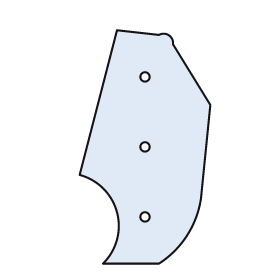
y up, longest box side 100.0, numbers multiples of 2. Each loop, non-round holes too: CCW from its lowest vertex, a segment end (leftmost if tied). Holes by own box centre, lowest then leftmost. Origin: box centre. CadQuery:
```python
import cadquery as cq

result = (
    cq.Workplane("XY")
    .moveTo(-18.0, -50.0)
    .lineTo(6.0, -50.0)
    .threePointArc((18.0, -38.0), (24.0, -22.0))
    .lineTo(28.0, 18.0)
    .lineTo(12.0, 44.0)
    .threePointArc((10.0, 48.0), (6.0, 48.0))
    .lineTo(-12.0, 50.0)
    .lineTo(-28.0, -12.0)
    .threePointArc((-12.0, -28.0), (-18.0, -50.0))
    .close()
    .moveTo(0.0, -30.0)
    .circle(2.0)
    .moveTo(0.0, 0.0)
    .circle(2.0)
    .moveTo(0.0, 30.0)
    .circle(2.0)
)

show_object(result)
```